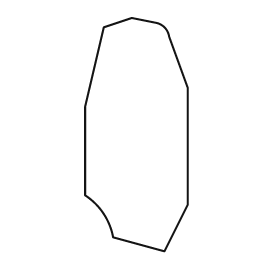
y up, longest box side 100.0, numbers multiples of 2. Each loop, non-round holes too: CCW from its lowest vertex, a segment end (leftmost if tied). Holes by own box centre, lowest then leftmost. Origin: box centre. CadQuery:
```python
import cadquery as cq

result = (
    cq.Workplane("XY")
    .moveTo(12.0, -50.0)
    .lineTo(22.0, -30.0)
    .lineTo(22.0, 20.0)
    .lineTo(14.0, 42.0)
    .threePointArc((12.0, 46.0), (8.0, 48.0))
    .lineTo(-2.0, 50.0)
    .lineTo(-14.0, 46.0)
    .lineTo(-22.0, 12.0)
    .lineTo(-22.0, -26.0)
    .threePointArc((-14.0, -34.0), (-10.0, -44.0))
    .close()
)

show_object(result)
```